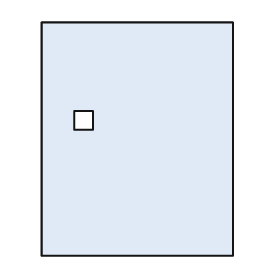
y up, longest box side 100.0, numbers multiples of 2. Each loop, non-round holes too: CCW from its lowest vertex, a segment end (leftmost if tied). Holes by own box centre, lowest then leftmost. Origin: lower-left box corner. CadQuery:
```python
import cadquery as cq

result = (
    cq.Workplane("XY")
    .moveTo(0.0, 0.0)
    .lineTo(82.0, 0.0)
    .lineTo(82.0, 100.0)
    .lineTo(0.0, 100.0)
    .close()
    .moveTo(14.0, 54.0)
    .lineTo(22.0, 54.0)
    .lineTo(22.0, 62.0)
    .lineTo(14.0, 62.0)
    .close()
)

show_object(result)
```